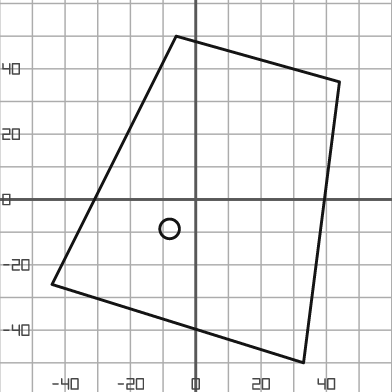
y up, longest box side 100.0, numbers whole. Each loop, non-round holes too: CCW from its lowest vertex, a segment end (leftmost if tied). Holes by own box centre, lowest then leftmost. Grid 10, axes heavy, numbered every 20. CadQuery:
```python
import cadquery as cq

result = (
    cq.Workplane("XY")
    .moveTo(33.0, -50.0)
    .lineTo(44.0, 36.0)
    .lineTo(-6.0, 50.0)
    .lineTo(-44.0, -26.0)
    .close()
    .moveTo(-8.0, -9.0)
    .circle(3.0)
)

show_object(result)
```